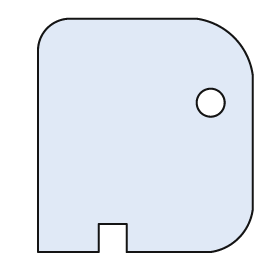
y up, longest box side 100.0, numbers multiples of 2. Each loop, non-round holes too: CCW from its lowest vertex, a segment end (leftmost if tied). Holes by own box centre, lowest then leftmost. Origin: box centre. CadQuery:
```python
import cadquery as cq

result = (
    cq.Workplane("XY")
    .moveTo(-46.0, -50.0)
    .lineTo(-20.0, -50.0)
    .lineTo(-20.0, -38.0)
    .lineTo(-8.0, -38.0)
    .lineTo(-8.0, -50.0)
    .lineTo(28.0, -50.0)
    .threePointArc((40.0, -44.0), (46.0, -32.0))
    .lineTo(46.0, 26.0)
    .threePointArc((38.0, 42.0), (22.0, 50.0))
    .lineTo(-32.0, 50.0)
    .threePointArc((-42.0, 46.0), (-46.0, 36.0))
    .close()
    .moveTo(28.0, 14.0)
    .circle(6.0)
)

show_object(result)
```